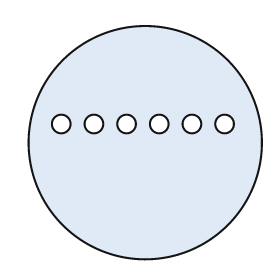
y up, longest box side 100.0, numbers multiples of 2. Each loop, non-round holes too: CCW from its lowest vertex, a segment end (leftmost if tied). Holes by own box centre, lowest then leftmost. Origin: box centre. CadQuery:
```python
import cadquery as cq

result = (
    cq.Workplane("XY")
    .moveTo(0.0, 0.0)
    .circle(50.0)
    .moveTo(-36.0, 8.0)
    .circle(4.0)
    .moveTo(-22.0, 8.0)
    .circle(4.0)
    .moveTo(-8.0, 8.0)
    .circle(4.0)
    .moveTo(6.0, 8.0)
    .circle(4.0)
    .moveTo(20.0, 8.0)
    .circle(4.0)
    .moveTo(34.0, 8.0)
    .circle(4.0)
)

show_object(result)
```